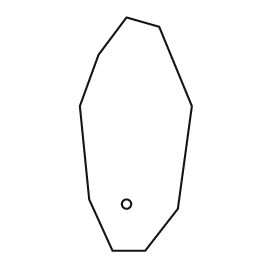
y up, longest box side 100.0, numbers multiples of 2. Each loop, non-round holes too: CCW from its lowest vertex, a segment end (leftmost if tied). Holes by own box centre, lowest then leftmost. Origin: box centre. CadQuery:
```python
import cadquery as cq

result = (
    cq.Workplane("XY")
    .moveTo(-10.0, -50.0)
    .lineTo(4.0, -50.0)
    .lineTo(18.0, -32.0)
    .lineTo(24.0, 12.0)
    .lineTo(10.0, 46.0)
    .lineTo(-4.0, 50.0)
    .lineTo(-16.0, 34.0)
    .lineTo(-24.0, 12.0)
    .lineTo(-20.0, -28.0)
    .close()
    .moveTo(-4.0, -30.0)
    .circle(2.0)
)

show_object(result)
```